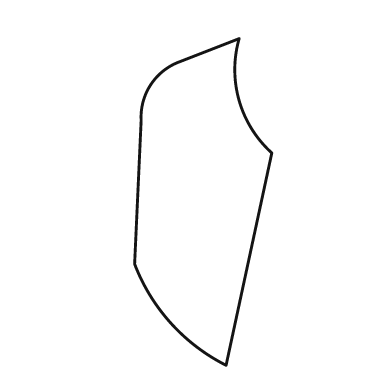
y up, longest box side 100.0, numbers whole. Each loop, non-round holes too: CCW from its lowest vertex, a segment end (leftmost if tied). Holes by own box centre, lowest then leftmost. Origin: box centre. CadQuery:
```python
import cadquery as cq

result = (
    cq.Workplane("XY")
    .moveTo(7.0, -50.0)
    .lineTo(21.0, 15.0)
    .threePointArc((11.0, 31.0), (11.0, 50.0))
    .lineTo(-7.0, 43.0)
    .threePointArc((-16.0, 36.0), (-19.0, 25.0))
    .lineTo(-21.0, -19.0)
    .threePointArc((-10.0, -37.0), (7.0, -50.0))
    .close()
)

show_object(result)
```